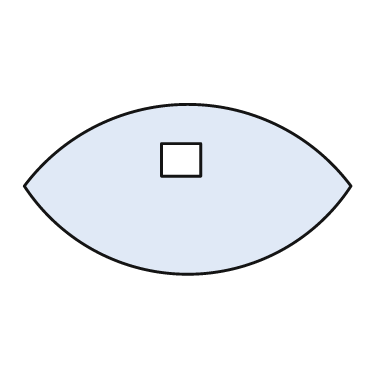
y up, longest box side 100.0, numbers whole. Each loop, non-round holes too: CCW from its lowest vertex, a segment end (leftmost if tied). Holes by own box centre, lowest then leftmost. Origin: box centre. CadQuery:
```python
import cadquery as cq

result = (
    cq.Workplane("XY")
    .moveTo(-50.0, 1.0)
    .threePointArc((0.0, -26.0), (50.0, 1.0))
    .threePointArc((0.0, 26.0), (-50.0, 1.0))
    .close()
    .moveTo(-8.0, 4.0)
    .lineTo(4.0, 4.0)
    .lineTo(4.0, 14.0)
    .lineTo(-8.0, 14.0)
    .close()
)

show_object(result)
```